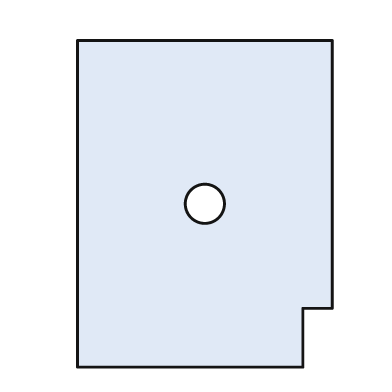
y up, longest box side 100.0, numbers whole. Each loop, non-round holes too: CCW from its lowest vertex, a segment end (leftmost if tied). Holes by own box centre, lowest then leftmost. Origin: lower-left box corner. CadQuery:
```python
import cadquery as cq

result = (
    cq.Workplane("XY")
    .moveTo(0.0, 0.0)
    .lineTo(69.0, 0.0)
    .lineTo(69.0, 18.0)
    .lineTo(78.0, 18.0)
    .lineTo(78.0, 100.0)
    .lineTo(0.0, 100.0)
    .close()
    .moveTo(39.0, 50.0)
    .circle(6.0)
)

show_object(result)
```